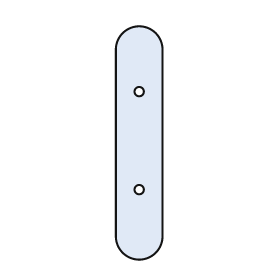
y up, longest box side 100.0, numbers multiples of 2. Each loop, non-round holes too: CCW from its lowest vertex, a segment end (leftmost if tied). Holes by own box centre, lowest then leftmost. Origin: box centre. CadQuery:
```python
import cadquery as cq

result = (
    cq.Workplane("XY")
    .moveTo(-10.0, -40.0)
    .threePointArc((0.0, -50.0), (10.0, -40.0))
    .lineTo(10.0, 40.0)
    .threePointArc((0.0, 50.0), (-10.0, 40.0))
    .close()
    .moveTo(0.0, -20.0)
    .circle(2.0)
    .moveTo(0.0, 22.0)
    .circle(2.0)
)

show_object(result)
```